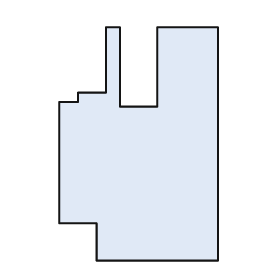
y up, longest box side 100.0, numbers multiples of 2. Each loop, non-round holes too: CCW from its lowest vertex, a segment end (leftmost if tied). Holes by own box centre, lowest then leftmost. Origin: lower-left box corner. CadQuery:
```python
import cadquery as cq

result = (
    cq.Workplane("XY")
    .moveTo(16.0, 0.0)
    .lineTo(68.0, 0.0)
    .lineTo(68.0, 100.0)
    .lineTo(42.0, 100.0)
    .lineTo(42.0, 66.0)
    .lineTo(26.0, 66.0)
    .lineTo(26.0, 100.0)
    .lineTo(20.0, 100.0)
    .lineTo(20.0, 72.0)
    .lineTo(8.0, 72.0)
    .lineTo(8.0, 68.0)
    .lineTo(0.0, 68.0)
    .lineTo(0.0, 16.0)
    .lineTo(16.0, 16.0)
    .close()
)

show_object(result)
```